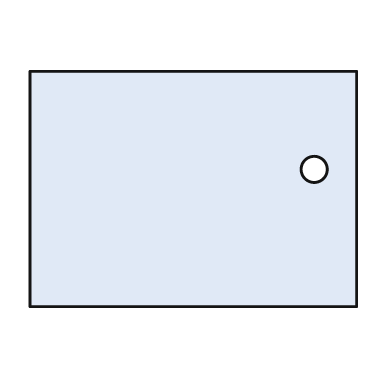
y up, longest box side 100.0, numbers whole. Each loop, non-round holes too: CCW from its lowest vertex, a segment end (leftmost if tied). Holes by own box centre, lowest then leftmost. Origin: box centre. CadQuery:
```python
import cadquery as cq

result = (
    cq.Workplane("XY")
    .moveTo(-50.0, -36.0)
    .lineTo(50.0, -36.0)
    .lineTo(50.0, 36.0)
    .lineTo(-50.0, 36.0)
    .close()
    .moveTo(37.0, 6.0)
    .circle(4.0)
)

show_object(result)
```